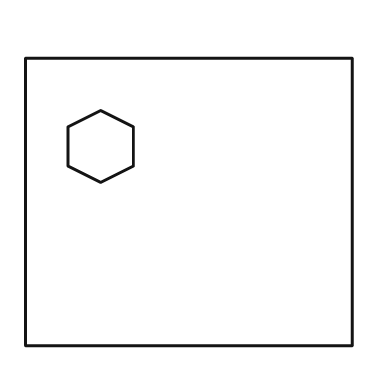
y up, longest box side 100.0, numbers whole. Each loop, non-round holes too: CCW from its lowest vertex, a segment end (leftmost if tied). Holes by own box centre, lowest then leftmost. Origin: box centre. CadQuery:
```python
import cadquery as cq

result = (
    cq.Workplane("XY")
    .moveTo(-50.0, -44.0)
    .lineTo(50.0, -44.0)
    .lineTo(50.0, 44.0)
    .lineTo(-50.0, 44.0)
    .close()
    .moveTo(-27.0, 6.0)
    .lineTo(-17.0, 11.0)
    .lineTo(-17.0, 23.0)
    .lineTo(-27.0, 28.0)
    .lineTo(-37.0, 23.0)
    .lineTo(-37.0, 11.0)
    .close()
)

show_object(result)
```